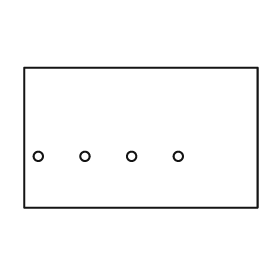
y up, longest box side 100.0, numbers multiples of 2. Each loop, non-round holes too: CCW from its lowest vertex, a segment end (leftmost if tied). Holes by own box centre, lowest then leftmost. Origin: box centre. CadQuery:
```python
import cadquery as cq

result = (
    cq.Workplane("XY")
    .moveTo(-50.0, -30.0)
    .lineTo(50.0, -30.0)
    .lineTo(50.0, 30.0)
    .lineTo(-50.0, 30.0)
    .close()
    .moveTo(-44.0, -8.0)
    .circle(2.0)
    .moveTo(-24.0, -8.0)
    .circle(2.0)
    .moveTo(-4.0, -8.0)
    .circle(2.0)
    .moveTo(16.0, -8.0)
    .circle(2.0)
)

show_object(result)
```